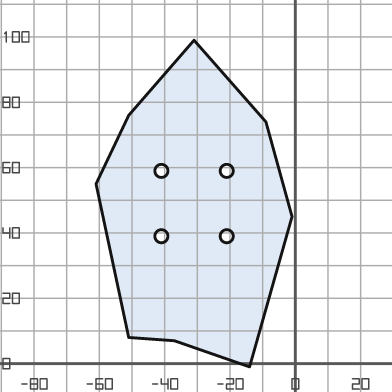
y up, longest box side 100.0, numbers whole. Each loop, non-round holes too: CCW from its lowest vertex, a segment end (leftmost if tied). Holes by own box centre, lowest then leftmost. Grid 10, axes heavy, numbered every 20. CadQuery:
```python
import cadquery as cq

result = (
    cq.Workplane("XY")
    .moveTo(-14.0, -1.0)
    .lineTo(-1.0, 45.0)
    .lineTo(-9.0, 74.0)
    .lineTo(-31.0, 99.0)
    .lineTo(-51.0, 76.0)
    .lineTo(-61.0, 55.0)
    .lineTo(-51.0, 8.0)
    .lineTo(-37.0, 7.0)
    .close()
    .moveTo(-41.0, 39.0)
    .circle(2.0)
    .moveTo(-21.0, 39.0)
    .circle(2.0)
    .moveTo(-41.0, 59.0)
    .circle(2.0)
    .moveTo(-21.0, 59.0)
    .circle(2.0)
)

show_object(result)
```